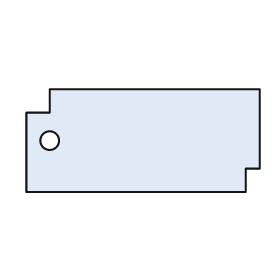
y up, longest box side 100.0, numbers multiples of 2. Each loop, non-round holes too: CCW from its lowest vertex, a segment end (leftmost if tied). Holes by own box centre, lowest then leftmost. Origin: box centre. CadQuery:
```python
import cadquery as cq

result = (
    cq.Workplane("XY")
    .moveTo(-50.0, -22.0)
    .lineTo(44.0, -22.0)
    .lineTo(44.0, -12.0)
    .lineTo(50.0, -12.0)
    .lineTo(50.0, 22.0)
    .lineTo(-40.0, 22.0)
    .lineTo(-40.0, 12.0)
    .lineTo(-50.0, 12.0)
    .close()
    .moveTo(-40.0, 0.0)
    .circle(4.0)
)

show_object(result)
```